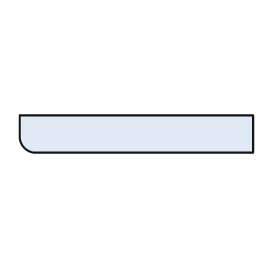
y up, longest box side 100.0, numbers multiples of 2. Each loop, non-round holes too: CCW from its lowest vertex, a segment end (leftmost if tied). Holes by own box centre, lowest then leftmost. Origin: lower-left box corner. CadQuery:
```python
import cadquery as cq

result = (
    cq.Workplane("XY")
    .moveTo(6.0, 0.0)
    .lineTo(100.0, 0.0)
    .lineTo(100.0, 16.0)
    .lineTo(0.0, 16.0)
    .lineTo(0.0, 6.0)
    .threePointArc((2.0, 2.0), (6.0, 0.0))
    .close()
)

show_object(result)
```